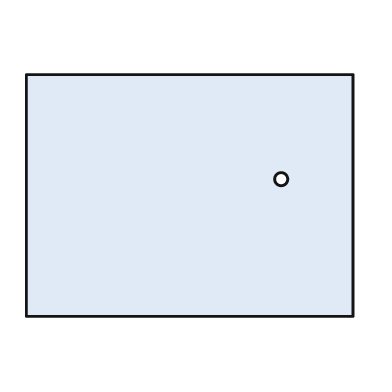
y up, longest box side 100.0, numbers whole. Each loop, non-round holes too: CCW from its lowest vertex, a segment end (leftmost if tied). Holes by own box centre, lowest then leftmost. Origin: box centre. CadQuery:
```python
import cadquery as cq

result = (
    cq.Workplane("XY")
    .moveTo(-50.0, -37.0)
    .lineTo(50.0, -37.0)
    .lineTo(50.0, 37.0)
    .lineTo(-50.0, 37.0)
    .close()
    .moveTo(28.0, 5.0)
    .circle(2.0)
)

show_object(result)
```